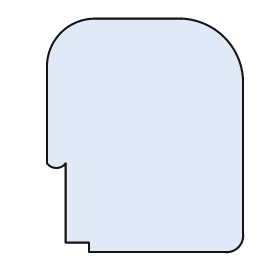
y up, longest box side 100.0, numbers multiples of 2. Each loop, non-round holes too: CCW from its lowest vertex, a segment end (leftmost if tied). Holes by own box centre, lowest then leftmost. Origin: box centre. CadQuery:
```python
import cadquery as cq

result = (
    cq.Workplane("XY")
    .moveTo(-24.0, -50.0)
    .lineTo(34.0, -50.0)
    .threePointArc((40.0, -48.0), (42.0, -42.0))
    .lineTo(42.0, 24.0)
    .threePointArc((34.0, 42.0), (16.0, 50.0))
    .lineTo(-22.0, 50.0)
    .threePointArc((-36.0, 44.0), (-42.0, 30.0))
    .lineTo(-42.0, -12.0)
    .threePointArc((-38.0, -14.0), (-34.0, -12.0))
    .lineTo(-34.0, -46.0)
    .lineTo(-24.0, -46.0)
    .close()
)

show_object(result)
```